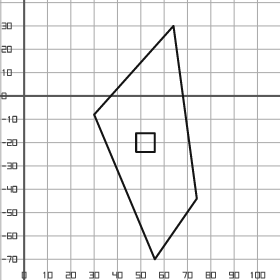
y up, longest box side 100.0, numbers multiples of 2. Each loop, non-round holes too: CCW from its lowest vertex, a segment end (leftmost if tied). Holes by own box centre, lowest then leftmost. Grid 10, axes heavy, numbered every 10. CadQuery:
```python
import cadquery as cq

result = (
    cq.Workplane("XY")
    .moveTo(56.0, -70.0)
    .lineTo(74.0, -44.0)
    .lineTo(64.0, 30.0)
    .lineTo(30.0, -8.0)
    .close()
    .moveTo(48.0, -24.0)
    .lineTo(56.0, -24.0)
    .lineTo(56.0, -16.0)
    .lineTo(48.0, -16.0)
    .close()
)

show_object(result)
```